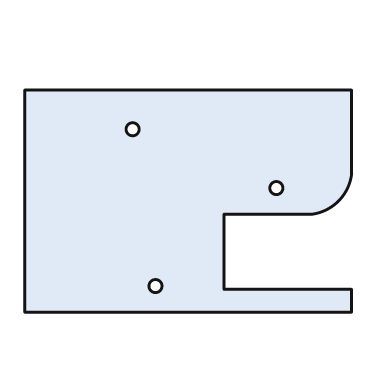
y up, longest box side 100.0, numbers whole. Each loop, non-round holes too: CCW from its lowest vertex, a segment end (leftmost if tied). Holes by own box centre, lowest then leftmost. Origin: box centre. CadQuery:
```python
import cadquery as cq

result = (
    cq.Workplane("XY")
    .moveTo(-50.0, -34.0)
    .lineTo(50.0, -34.0)
    .lineTo(50.0, -27.0)
    .lineTo(11.0, -27.0)
    .lineTo(11.0, -4.0)
    .lineTo(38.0, -4.0)
    .threePointArc((46.0, 0.0), (50.0, 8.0))
    .lineTo(50.0, 34.0)
    .lineTo(-50.0, 34.0)
    .close()
    .moveTo(-10.0, -26.0)
    .circle(2.0)
    .moveTo(27.0, 4.0)
    .circle(2.0)
    .moveTo(-17.0, 22.0)
    .circle(2.0)
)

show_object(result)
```